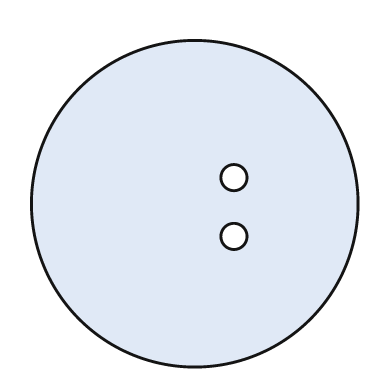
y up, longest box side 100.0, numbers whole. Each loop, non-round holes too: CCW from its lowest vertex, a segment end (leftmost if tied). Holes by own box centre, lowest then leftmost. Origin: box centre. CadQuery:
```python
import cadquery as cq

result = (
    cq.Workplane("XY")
    .moveTo(0.0, 0.0)
    .circle(50.0)
    .moveTo(12.0, -10.0)
    .circle(4.0)
    .moveTo(12.0, 8.0)
    .circle(4.0)
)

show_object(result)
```